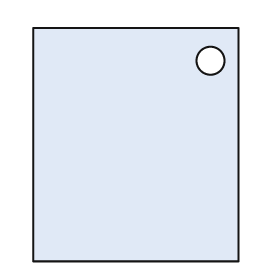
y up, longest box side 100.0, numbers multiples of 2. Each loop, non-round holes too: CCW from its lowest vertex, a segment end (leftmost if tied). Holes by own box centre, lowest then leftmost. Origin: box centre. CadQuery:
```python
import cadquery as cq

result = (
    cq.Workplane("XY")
    .moveTo(-44.0, -50.0)
    .lineTo(44.0, -50.0)
    .lineTo(44.0, 50.0)
    .lineTo(-44.0, 50.0)
    .close()
    .moveTo(32.0, 36.0)
    .circle(6.0)
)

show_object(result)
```